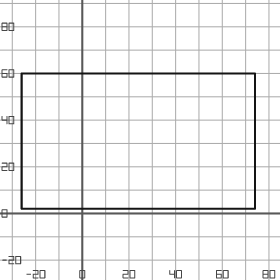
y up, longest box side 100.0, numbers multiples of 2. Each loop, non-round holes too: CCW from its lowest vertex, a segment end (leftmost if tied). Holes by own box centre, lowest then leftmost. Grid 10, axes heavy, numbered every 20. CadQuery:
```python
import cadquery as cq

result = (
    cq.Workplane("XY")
    .moveTo(-26.0, 2.0)
    .lineTo(74.0, 2.0)
    .lineTo(74.0, 60.0)
    .lineTo(-26.0, 60.0)
    .close()
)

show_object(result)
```